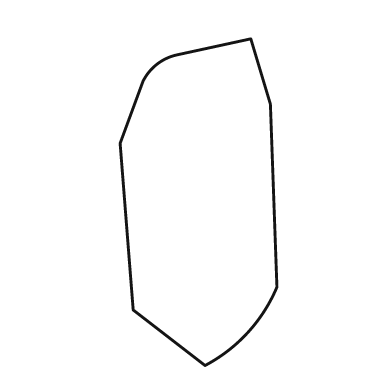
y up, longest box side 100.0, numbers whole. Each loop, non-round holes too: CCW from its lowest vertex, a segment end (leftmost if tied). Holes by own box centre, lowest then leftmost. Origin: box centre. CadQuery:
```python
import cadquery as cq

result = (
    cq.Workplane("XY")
    .moveTo(2.0, -50.0)
    .threePointArc((15.0, -40.0), (24.0, -26.0))
    .lineTo(22.0, 30.0)
    .lineTo(16.0, 50.0)
    .lineTo(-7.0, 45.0)
    .threePointArc((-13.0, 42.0), (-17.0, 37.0))
    .lineTo(-24.0, 18.0)
    .lineTo(-20.0, -33.0)
    .close()
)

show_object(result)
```